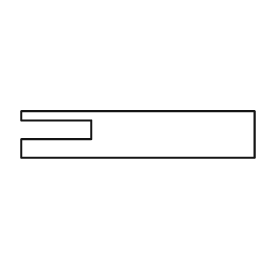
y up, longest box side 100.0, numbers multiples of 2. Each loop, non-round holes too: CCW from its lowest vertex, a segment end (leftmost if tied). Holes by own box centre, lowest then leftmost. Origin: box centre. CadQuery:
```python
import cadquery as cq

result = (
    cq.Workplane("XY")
    .moveTo(-50.0, -10.0)
    .lineTo(50.0, -10.0)
    .lineTo(50.0, 10.0)
    .lineTo(-50.0, 10.0)
    .lineTo(-50.0, 6.0)
    .lineTo(-20.0, 6.0)
    .lineTo(-20.0, -2.0)
    .lineTo(-50.0, -2.0)
    .close()
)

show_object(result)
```